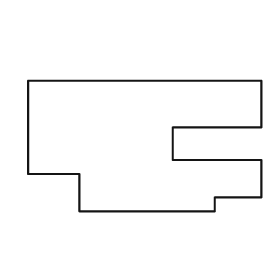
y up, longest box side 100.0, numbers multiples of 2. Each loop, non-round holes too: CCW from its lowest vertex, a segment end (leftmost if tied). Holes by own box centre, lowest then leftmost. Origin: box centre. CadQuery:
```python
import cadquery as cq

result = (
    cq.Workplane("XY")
    .moveTo(-28.0, -28.0)
    .lineTo(30.0, -28.0)
    .lineTo(30.0, -22.0)
    .lineTo(50.0, -22.0)
    .lineTo(50.0, -6.0)
    .lineTo(12.0, -6.0)
    .lineTo(12.0, 8.0)
    .lineTo(50.0, 8.0)
    .lineTo(50.0, 28.0)
    .lineTo(-50.0, 28.0)
    .lineTo(-50.0, -12.0)
    .lineTo(-28.0, -12.0)
    .close()
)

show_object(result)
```